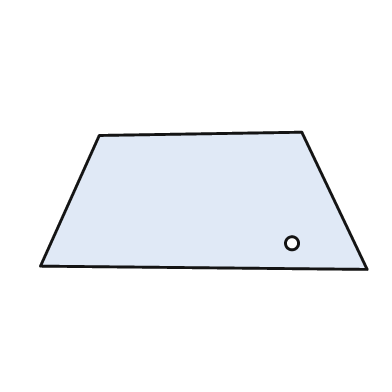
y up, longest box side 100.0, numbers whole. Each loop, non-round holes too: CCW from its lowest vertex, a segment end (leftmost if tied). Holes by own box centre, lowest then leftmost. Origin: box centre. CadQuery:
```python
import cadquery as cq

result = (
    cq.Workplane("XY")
    .moveTo(50.0, -21.0)
    .lineTo(30.0, 21.0)
    .lineTo(-32.0, 20.0)
    .lineTo(-50.0, -20.0)
    .close()
    .moveTo(27.0, -13.0)
    .circle(2.0)
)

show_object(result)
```